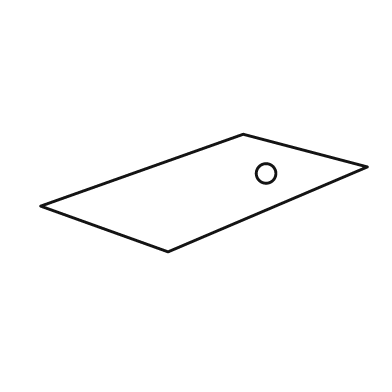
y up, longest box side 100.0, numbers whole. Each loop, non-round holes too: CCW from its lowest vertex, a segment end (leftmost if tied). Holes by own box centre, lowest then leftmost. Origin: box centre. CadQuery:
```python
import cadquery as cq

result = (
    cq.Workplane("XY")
    .moveTo(-11.0, -18.0)
    .lineTo(50.0, 8.0)
    .lineTo(12.0, 18.0)
    .lineTo(-50.0, -4.0)
    .close()
    .moveTo(19.0, 6.0)
    .circle(3.0)
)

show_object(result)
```